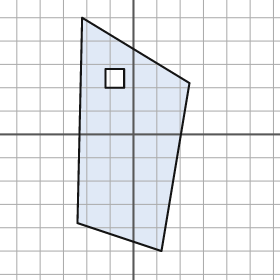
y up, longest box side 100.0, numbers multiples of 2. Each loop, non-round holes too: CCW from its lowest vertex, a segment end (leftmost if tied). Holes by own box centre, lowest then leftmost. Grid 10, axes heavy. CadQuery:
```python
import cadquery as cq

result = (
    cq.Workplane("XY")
    .moveTo(12.0, -50.0)
    .lineTo(24.0, 22.0)
    .lineTo(-22.0, 50.0)
    .lineTo(-24.0, -38.0)
    .close()
    .moveTo(-12.0, 20.0)
    .lineTo(-4.0, 20.0)
    .lineTo(-4.0, 28.0)
    .lineTo(-12.0, 28.0)
    .close()
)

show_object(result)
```